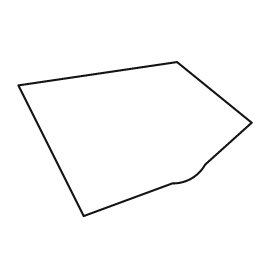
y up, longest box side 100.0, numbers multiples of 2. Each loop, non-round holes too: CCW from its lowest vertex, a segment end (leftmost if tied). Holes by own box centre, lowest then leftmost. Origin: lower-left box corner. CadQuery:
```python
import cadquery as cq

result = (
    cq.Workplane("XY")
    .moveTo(28.0, 0.0)
    .lineTo(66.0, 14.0)
    .threePointArc((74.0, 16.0), (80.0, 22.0))
    .lineTo(100.0, 40.0)
    .lineTo(68.0, 66.0)
    .lineTo(0.0, 56.0)
    .close()
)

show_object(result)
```